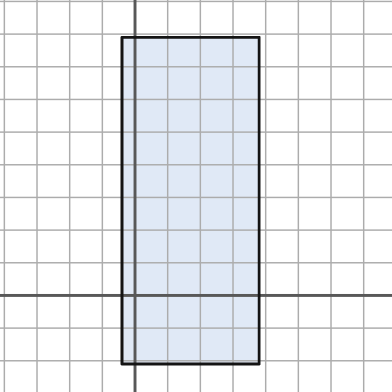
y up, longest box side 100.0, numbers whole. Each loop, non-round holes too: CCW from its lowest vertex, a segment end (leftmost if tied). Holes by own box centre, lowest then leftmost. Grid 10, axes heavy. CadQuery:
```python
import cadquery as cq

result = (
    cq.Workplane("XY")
    .moveTo(-4.0, -21.0)
    .lineTo(38.0, -21.0)
    .lineTo(38.0, 79.0)
    .lineTo(-4.0, 79.0)
    .close()
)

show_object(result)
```